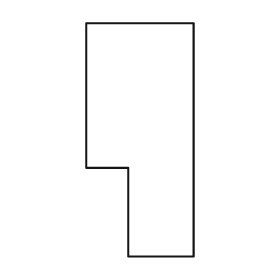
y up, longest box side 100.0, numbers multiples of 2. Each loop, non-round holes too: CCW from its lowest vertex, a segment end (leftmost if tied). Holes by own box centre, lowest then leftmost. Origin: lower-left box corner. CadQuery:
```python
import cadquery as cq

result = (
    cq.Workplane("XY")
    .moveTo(18.0, 0.0)
    .lineTo(46.0, 0.0)
    .lineTo(46.0, 100.0)
    .lineTo(0.0, 100.0)
    .lineTo(0.0, 38.0)
    .lineTo(18.0, 38.0)
    .close()
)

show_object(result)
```